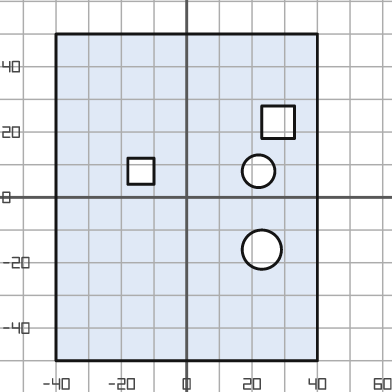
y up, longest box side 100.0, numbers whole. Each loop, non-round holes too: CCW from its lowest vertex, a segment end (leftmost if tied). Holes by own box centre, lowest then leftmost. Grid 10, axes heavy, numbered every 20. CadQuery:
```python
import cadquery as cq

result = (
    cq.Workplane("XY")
    .moveTo(-40.0, -50.0)
    .lineTo(40.0, -50.0)
    .lineTo(40.0, 50.0)
    .lineTo(-40.0, 50.0)
    .close()
    .moveTo(23.0, -16.0)
    .circle(6.0)
    .moveTo(-18.0, 4.0)
    .lineTo(-10.0, 4.0)
    .lineTo(-10.0, 12.0)
    .lineTo(-18.0, 12.0)
    .close()
    .moveTo(22.0, 8.0)
    .circle(5.0)
    .moveTo(23.0, 18.0)
    .lineTo(33.0, 18.0)
    .lineTo(33.0, 28.0)
    .lineTo(23.0, 28.0)
    .close()
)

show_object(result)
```